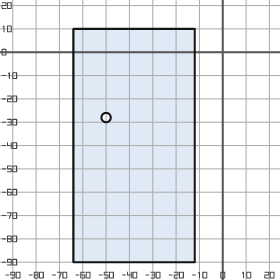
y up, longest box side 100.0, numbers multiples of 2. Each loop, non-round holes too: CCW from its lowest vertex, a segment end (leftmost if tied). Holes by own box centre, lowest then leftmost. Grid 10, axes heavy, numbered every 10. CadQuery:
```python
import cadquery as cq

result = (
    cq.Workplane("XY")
    .moveTo(-64.0, -90.0)
    .lineTo(-12.0, -90.0)
    .lineTo(-12.0, 10.0)
    .lineTo(-64.0, 10.0)
    .close()
    .moveTo(-50.0, -28.0)
    .circle(2.0)
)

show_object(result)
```